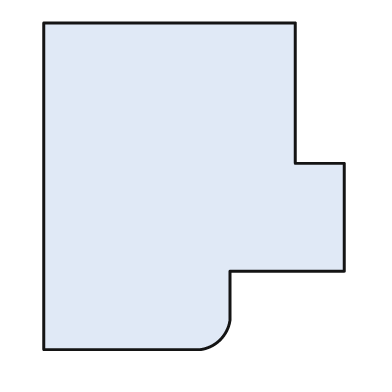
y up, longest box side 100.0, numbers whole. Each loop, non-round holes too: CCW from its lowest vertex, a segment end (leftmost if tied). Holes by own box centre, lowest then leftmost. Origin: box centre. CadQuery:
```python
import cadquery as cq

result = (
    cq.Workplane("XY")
    .moveTo(-46.0, -50.0)
    .lineTo(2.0, -50.0)
    .threePointArc((8.0, -47.0), (11.0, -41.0))
    .lineTo(11.0, -26.0)
    .lineTo(46.0, -26.0)
    .lineTo(46.0, 7.0)
    .lineTo(31.0, 7.0)
    .lineTo(31.0, 50.0)
    .lineTo(-46.0, 50.0)
    .close()
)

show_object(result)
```